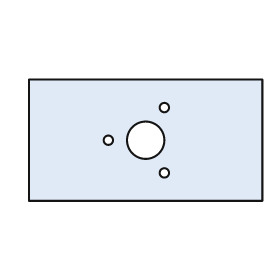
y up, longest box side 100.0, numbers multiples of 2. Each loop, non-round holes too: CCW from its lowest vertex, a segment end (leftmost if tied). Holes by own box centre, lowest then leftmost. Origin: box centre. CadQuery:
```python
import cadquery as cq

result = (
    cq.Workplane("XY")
    .moveTo(-50.0, -26.0)
    .lineTo(50.0, -26.0)
    .lineTo(50.0, 26.0)
    .lineTo(-50.0, 26.0)
    .close()
    .moveTo(8.0, -14.0)
    .circle(2.0)
    .moveTo(-16.0, 0.0)
    .circle(2.0)
    .moveTo(0.0, 0.0)
    .circle(8.0)
    .moveTo(8.0, 14.0)
    .circle(2.0)
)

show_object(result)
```